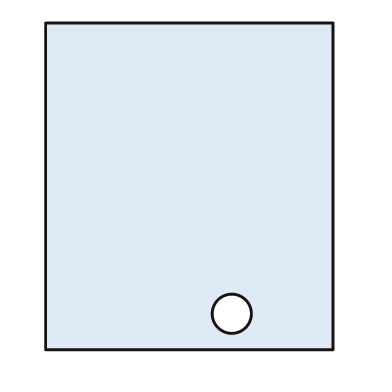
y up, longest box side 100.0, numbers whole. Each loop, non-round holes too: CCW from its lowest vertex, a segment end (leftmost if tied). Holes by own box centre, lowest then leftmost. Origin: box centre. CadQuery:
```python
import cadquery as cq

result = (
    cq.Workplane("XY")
    .moveTo(-44.0, -50.0)
    .lineTo(44.0, -50.0)
    .lineTo(44.0, 50.0)
    .lineTo(-44.0, 50.0)
    .close()
    .moveTo(13.0, -39.0)
    .circle(6.0)
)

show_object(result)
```